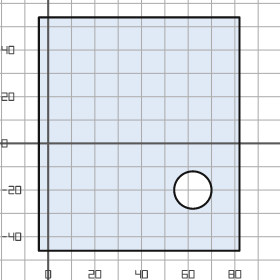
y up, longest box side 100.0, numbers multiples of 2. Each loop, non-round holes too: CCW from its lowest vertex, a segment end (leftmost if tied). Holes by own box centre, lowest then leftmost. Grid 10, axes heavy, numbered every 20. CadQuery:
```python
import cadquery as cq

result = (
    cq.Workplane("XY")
    .moveTo(-4.0, -46.0)
    .lineTo(82.0, -46.0)
    .lineTo(82.0, 54.0)
    .lineTo(-4.0, 54.0)
    .close()
    .moveTo(62.0, -20.0)
    .circle(8.0)
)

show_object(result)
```